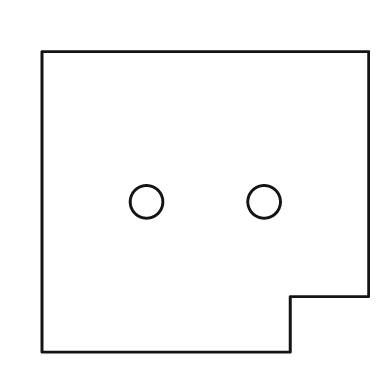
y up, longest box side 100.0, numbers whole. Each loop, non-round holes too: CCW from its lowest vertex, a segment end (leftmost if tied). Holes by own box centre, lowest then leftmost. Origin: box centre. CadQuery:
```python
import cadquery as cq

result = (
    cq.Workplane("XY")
    .moveTo(-50.0, -46.0)
    .lineTo(26.0, -46.0)
    .lineTo(26.0, -29.0)
    .lineTo(50.0, -29.0)
    .lineTo(50.0, 46.0)
    .lineTo(-50.0, 46.0)
    .close()
    .moveTo(-18.0, 0.0)
    .circle(5.0)
    .moveTo(18.0, 0.0)
    .circle(5.0)
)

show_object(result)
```